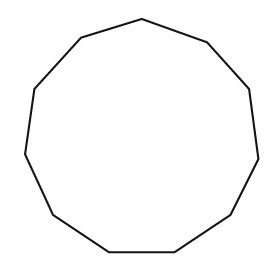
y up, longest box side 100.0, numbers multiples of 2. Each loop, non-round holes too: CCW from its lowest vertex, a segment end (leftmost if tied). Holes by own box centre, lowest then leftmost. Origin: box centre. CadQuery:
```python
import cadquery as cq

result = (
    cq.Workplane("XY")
    .moveTo(-14.0, -50.0)
    .lineTo(14.0, -50.0)
    .lineTo(38.0, -34.0)
    .lineTo(50.0, -10.0)
    .lineTo(46.0, 20.0)
    .lineTo(28.0, 40.0)
    .lineTo(0.0, 50.0)
    .lineTo(-26.0, 42.0)
    .lineTo(-46.0, 20.0)
    .lineTo(-50.0, -8.0)
    .lineTo(-38.0, -34.0)
    .close()
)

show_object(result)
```